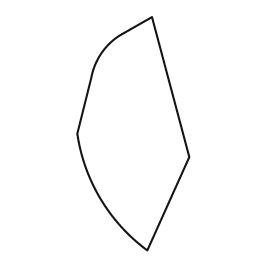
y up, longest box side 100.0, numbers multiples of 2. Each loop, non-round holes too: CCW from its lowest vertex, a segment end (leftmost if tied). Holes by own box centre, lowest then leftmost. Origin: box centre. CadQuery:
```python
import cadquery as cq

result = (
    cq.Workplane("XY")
    .moveTo(6.0, -50.0)
    .lineTo(24.0, -10.0)
    .lineTo(8.0, 50.0)
    .lineTo(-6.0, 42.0)
    .threePointArc((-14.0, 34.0), (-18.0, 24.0))
    .lineTo(-24.0, 0.0)
    .threePointArc((-14.0, -28.0), (6.0, -50.0))
    .close()
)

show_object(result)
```